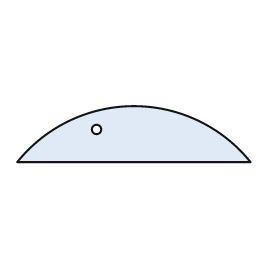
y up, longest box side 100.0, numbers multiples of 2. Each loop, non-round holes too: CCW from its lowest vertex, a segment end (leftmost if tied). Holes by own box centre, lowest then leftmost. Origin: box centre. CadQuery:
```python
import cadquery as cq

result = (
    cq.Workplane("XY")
    .moveTo(-50.0, -12.0)
    .lineTo(50.0, -12.0)
    .threePointArc((0.0, 12.0), (-50.0, -12.0))
    .close()
    .moveTo(-16.0, 2.0)
    .circle(2.0)
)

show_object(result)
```